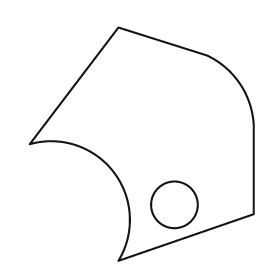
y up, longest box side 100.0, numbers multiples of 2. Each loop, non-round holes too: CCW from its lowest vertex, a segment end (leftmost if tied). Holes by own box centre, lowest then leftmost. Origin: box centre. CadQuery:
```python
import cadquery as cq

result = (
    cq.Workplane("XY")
    .moveTo(-10.0, -50.0)
    .lineTo(48.0, -30.0)
    .lineTo(48.0, 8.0)
    .threePointArc((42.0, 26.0), (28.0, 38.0))
    .lineTo(-10.0, 50.0)
    .lineTo(-48.0, 0.0)
    .threePointArc((-12.0, -12.0), (-10.0, -50.0))
    .close()
    .moveTo(14.0, -26.0)
    .circle(10.0)
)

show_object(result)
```